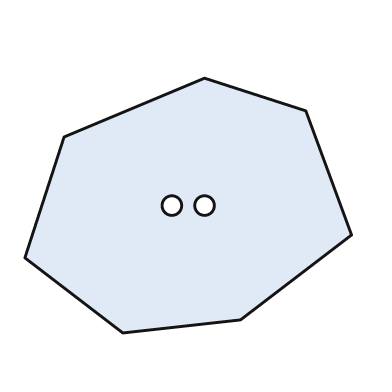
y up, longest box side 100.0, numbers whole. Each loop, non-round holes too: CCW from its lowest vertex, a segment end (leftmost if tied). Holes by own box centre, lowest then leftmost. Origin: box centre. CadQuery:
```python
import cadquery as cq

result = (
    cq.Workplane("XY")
    .moveTo(-20.0, -39.0)
    .lineTo(16.0, -35.0)
    .lineTo(50.0, -9.0)
    .lineTo(36.0, 29.0)
    .lineTo(5.0, 39.0)
    .lineTo(-38.0, 21.0)
    .lineTo(-50.0, -16.0)
    .close()
    .moveTo(-5.0, 0.0)
    .circle(3.0)
    .moveTo(5.0, 0.0)
    .circle(3.0)
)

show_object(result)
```